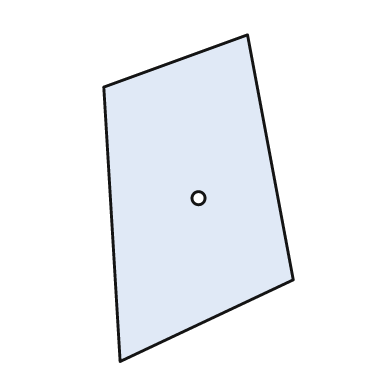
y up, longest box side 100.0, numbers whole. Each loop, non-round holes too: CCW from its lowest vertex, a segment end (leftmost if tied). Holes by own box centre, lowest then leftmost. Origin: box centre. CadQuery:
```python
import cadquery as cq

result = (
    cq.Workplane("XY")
    .moveTo(-24.0, -50.0)
    .lineTo(29.0, -25.0)
    .lineTo(15.0, 50.0)
    .lineTo(-29.0, 34.0)
    .close()
    .moveTo(0.0, 0.0)
    .circle(2.0)
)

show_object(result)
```